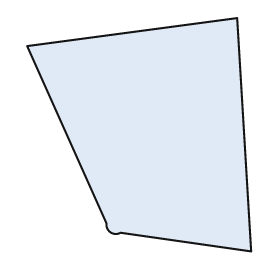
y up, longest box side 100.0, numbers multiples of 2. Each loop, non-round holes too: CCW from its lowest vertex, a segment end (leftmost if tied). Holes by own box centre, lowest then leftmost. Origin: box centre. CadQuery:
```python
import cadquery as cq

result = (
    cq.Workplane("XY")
    .moveTo(48.0, -50.0)
    .lineTo(42.0, 50.0)
    .lineTo(-48.0, 38.0)
    .lineTo(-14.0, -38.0)
    .threePointArc((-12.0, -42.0), (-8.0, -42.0))
    .close()
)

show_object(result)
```